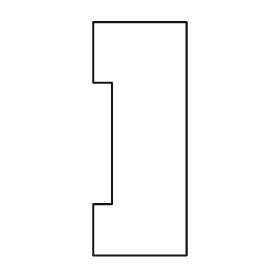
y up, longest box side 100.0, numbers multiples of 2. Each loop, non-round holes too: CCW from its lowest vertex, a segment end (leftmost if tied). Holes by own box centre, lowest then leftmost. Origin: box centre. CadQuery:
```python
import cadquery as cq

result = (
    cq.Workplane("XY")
    .moveTo(-20.0, -50.0)
    .lineTo(20.0, -50.0)
    .lineTo(20.0, 50.0)
    .lineTo(-20.0, 50.0)
    .lineTo(-20.0, 24.0)
    .lineTo(-12.0, 24.0)
    .lineTo(-12.0, -28.0)
    .lineTo(-20.0, -28.0)
    .close()
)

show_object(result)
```